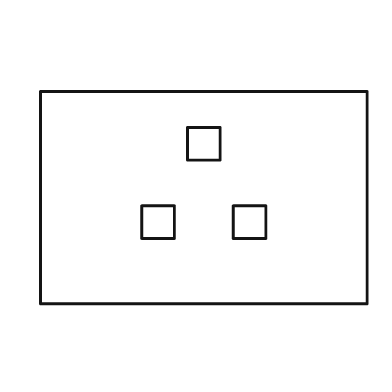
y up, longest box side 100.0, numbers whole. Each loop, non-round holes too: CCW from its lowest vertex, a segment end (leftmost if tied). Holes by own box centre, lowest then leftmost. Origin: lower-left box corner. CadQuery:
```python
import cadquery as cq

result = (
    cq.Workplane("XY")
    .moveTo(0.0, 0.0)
    .lineTo(100.0, 0.0)
    .lineTo(100.0, 65.0)
    .lineTo(0.0, 65.0)
    .close()
    .moveTo(31.0, 20.0)
    .lineTo(41.0, 20.0)
    .lineTo(41.0, 30.0)
    .lineTo(31.0, 30.0)
    .close()
    .moveTo(59.0, 20.0)
    .lineTo(69.0, 20.0)
    .lineTo(69.0, 30.0)
    .lineTo(59.0, 30.0)
    .close()
    .moveTo(45.0, 44.0)
    .lineTo(55.0, 44.0)
    .lineTo(55.0, 54.0)
    .lineTo(45.0, 54.0)
    .close()
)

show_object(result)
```